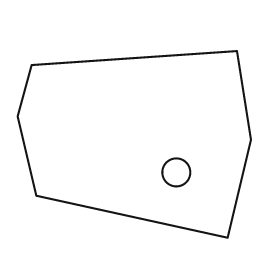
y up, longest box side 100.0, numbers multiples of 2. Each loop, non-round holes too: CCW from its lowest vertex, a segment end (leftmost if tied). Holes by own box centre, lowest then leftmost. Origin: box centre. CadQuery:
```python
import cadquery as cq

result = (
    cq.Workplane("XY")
    .moveTo(40.0, -40.0)
    .lineTo(50.0, 2.0)
    .lineTo(44.0, 40.0)
    .lineTo(-44.0, 34.0)
    .lineTo(-50.0, 12.0)
    .lineTo(-42.0, -22.0)
    .close()
    .moveTo(18.0, -12.0)
    .circle(6.0)
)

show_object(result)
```